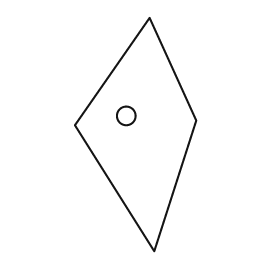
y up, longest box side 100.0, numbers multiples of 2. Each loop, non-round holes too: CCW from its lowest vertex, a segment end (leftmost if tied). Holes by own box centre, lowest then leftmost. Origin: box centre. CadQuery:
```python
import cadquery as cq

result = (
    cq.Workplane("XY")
    .moveTo(8.0, -50.0)
    .lineTo(26.0, 6.0)
    .lineTo(6.0, 50.0)
    .lineTo(-26.0, 4.0)
    .close()
    .moveTo(-4.0, 8.0)
    .circle(4.0)
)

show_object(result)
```